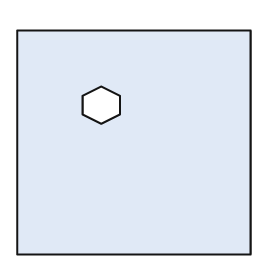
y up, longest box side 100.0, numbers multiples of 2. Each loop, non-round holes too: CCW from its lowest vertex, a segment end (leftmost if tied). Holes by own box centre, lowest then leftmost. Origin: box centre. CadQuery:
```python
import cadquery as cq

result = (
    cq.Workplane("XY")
    .moveTo(-50.0, -48.0)
    .lineTo(50.0, -48.0)
    .lineTo(50.0, 48.0)
    .lineTo(-50.0, 48.0)
    .close()
    .moveTo(-14.0, 8.0)
    .lineTo(-6.0, 12.0)
    .lineTo(-6.0, 20.0)
    .lineTo(-14.0, 24.0)
    .lineTo(-22.0, 20.0)
    .lineTo(-22.0, 12.0)
    .close()
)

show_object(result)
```